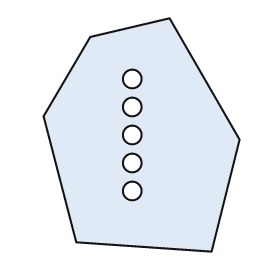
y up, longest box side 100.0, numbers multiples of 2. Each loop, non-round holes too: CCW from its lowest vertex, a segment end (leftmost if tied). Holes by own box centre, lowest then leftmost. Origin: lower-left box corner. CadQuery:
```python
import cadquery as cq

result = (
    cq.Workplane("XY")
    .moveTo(72.0, 0.0)
    .lineTo(84.0, 48.0)
    .lineTo(54.0, 100.0)
    .lineTo(20.0, 92.0)
    .lineTo(0.0, 58.0)
    .lineTo(14.0, 4.0)
    .close()
    .moveTo(38.0, 26.0)
    .circle(4.0)
    .moveTo(38.0, 38.0)
    .circle(4.0)
    .moveTo(38.0, 50.0)
    .circle(4.0)
    .moveTo(38.0, 62.0)
    .circle(4.0)
    .moveTo(38.0, 74.0)
    .circle(4.0)
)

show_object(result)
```